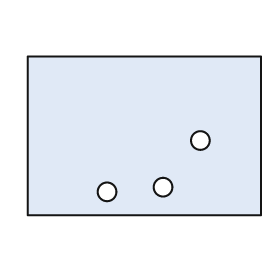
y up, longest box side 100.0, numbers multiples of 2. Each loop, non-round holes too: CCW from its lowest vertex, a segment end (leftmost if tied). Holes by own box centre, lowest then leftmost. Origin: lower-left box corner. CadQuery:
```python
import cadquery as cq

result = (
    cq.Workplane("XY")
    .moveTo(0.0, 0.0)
    .lineTo(100.0, 0.0)
    .lineTo(100.0, 68.0)
    .lineTo(0.0, 68.0)
    .close()
    .moveTo(34.0, 10.0)
    .circle(4.0)
    .moveTo(58.0, 12.0)
    .circle(4.0)
    .moveTo(74.0, 32.0)
    .circle(4.0)
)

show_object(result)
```